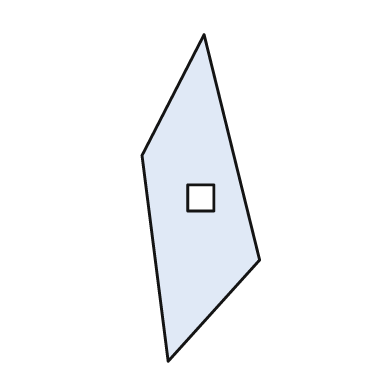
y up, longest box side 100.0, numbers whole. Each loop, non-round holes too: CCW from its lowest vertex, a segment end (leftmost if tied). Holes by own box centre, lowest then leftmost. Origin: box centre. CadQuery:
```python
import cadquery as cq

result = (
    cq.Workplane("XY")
    .moveTo(-10.0, -50.0)
    .lineTo(18.0, -19.0)
    .lineTo(1.0, 50.0)
    .lineTo(-18.0, 13.0)
    .close()
    .moveTo(-4.0, -4.0)
    .lineTo(4.0, -4.0)
    .lineTo(4.0, 4.0)
    .lineTo(-4.0, 4.0)
    .close()
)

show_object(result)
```